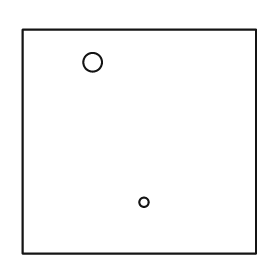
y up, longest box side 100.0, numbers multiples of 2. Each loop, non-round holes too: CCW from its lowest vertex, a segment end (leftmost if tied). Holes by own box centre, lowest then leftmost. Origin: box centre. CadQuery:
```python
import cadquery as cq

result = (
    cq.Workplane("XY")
    .moveTo(-50.0, -48.0)
    .lineTo(50.0, -48.0)
    .lineTo(50.0, 48.0)
    .lineTo(-50.0, 48.0)
    .close()
    .moveTo(2.0, -26.0)
    .circle(2.0)
    .moveTo(-20.0, 34.0)
    .circle(4.0)
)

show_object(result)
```